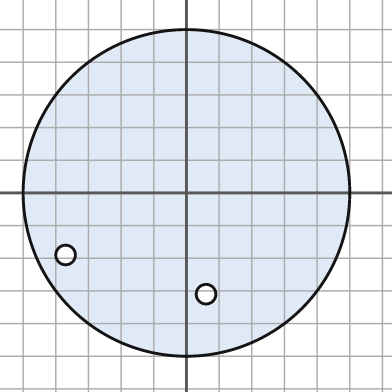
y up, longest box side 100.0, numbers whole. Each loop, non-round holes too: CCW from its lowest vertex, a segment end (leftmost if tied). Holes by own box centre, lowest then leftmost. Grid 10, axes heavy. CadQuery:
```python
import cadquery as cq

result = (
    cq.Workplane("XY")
    .moveTo(0.0, 0.0)
    .circle(50.0)
    .moveTo(6.0, -31.0)
    .circle(3.0)
    .moveTo(-37.0, -19.0)
    .circle(3.0)
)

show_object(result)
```